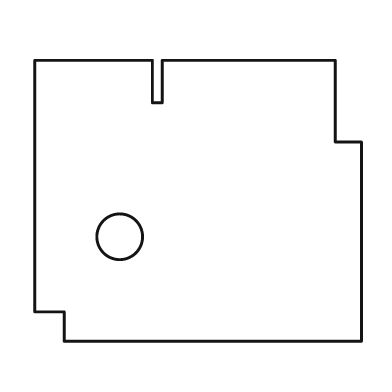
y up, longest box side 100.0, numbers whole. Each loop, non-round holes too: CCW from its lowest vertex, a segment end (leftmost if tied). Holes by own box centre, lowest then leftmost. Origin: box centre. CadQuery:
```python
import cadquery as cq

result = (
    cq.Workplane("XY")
    .moveTo(-41.0, -43.0)
    .lineTo(50.0, -43.0)
    .lineTo(50.0, 18.0)
    .lineTo(42.0, 18.0)
    .lineTo(42.0, 43.0)
    .lineTo(-11.0, 43.0)
    .lineTo(-11.0, 30.0)
    .lineTo(-14.0, 30.0)
    .lineTo(-14.0, 43.0)
    .lineTo(-50.0, 43.0)
    .lineTo(-50.0, -34.0)
    .lineTo(-41.0, -34.0)
    .close()
    .moveTo(-24.0, -11.0)
    .circle(7.0)
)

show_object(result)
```